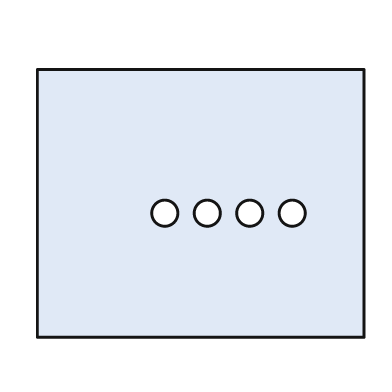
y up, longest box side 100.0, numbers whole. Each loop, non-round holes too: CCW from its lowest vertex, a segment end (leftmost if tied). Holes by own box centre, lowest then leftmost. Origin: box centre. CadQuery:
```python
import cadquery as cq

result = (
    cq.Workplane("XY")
    .moveTo(-50.0, -41.0)
    .lineTo(50.0, -41.0)
    .lineTo(50.0, 41.0)
    .lineTo(-50.0, 41.0)
    .close()
    .moveTo(-11.0, -3.0)
    .circle(4.0)
    .moveTo(2.0, -3.0)
    .circle(4.0)
    .moveTo(15.0, -3.0)
    .circle(4.0)
    .moveTo(28.0, -3.0)
    .circle(4.0)
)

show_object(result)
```